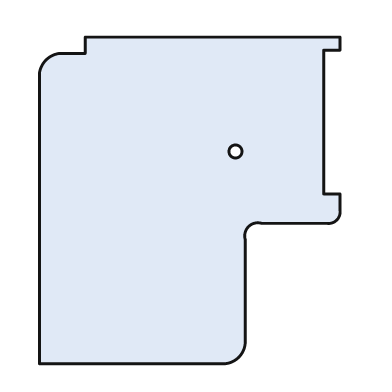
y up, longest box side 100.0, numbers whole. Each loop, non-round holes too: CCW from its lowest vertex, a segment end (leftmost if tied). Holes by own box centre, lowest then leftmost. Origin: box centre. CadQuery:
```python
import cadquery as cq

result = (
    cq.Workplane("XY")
    .moveTo(-46.0, -50.0)
    .lineTo(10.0, -50.0)
    .threePointArc((15.0, -48.0), (17.0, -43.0))
    .lineTo(17.0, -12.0)
    .threePointArc((18.0, -8.0), (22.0, -7.0))
    .lineTo(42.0, -7.0)
    .threePointArc((45.0, -6.0), (46.0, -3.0))
    .lineTo(46.0, 2.0)
    .lineTo(41.0, 2.0)
    .lineTo(41.0, 46.0)
    .lineTo(46.0, 46.0)
    .lineTo(46.0, 50.0)
    .lineTo(-32.0, 50.0)
    .lineTo(-32.0, 45.0)
    .lineTo(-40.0, 45.0)
    .threePointArc((-44.0, 43.0), (-46.0, 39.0))
    .close()
    .moveTo(14.0, 15.0)
    .circle(2.0)
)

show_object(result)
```